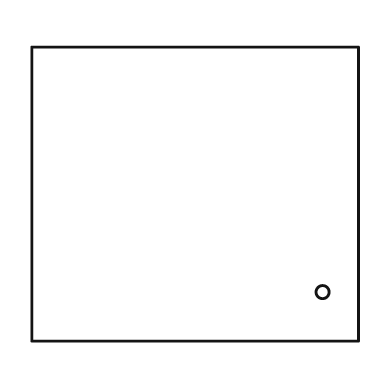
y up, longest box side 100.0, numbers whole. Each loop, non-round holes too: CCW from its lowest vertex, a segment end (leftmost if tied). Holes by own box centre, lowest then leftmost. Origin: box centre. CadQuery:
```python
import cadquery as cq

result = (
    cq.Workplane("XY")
    .moveTo(-50.0, -45.0)
    .lineTo(50.0, -45.0)
    .lineTo(50.0, 45.0)
    .lineTo(-50.0, 45.0)
    .close()
    .moveTo(39.0, -30.0)
    .circle(2.0)
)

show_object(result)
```